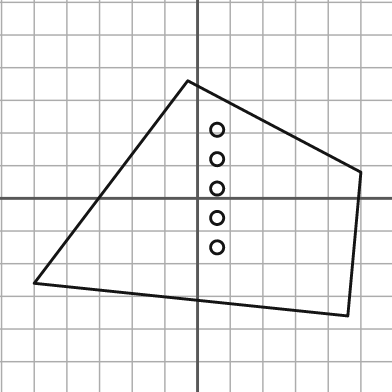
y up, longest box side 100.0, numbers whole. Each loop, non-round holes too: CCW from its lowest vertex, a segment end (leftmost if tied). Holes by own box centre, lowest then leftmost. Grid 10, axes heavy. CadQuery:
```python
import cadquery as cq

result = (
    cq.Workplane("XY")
    .moveTo(46.0, -36.0)
    .lineTo(50.0, 8.0)
    .lineTo(-3.0, 36.0)
    .lineTo(-50.0, -26.0)
    .close()
    .moveTo(6.0, -15.0)
    .circle(2.0)
    .moveTo(6.0, -6.0)
    .circle(2.0)
    .moveTo(6.0, 3.0)
    .circle(2.0)
    .moveTo(6.0, 12.0)
    .circle(2.0)
    .moveTo(6.0, 21.0)
    .circle(2.0)
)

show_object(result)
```